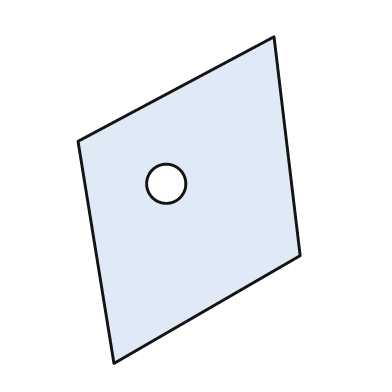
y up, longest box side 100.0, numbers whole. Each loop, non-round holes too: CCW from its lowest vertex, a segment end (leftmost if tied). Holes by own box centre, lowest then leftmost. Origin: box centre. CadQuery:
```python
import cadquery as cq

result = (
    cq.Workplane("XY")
    .moveTo(-23.0, -50.0)
    .lineTo(34.0, -17.0)
    .lineTo(26.0, 50.0)
    .lineTo(-34.0, 18.0)
    .close()
    .moveTo(-7.0, 5.0)
    .circle(6.0)
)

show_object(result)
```